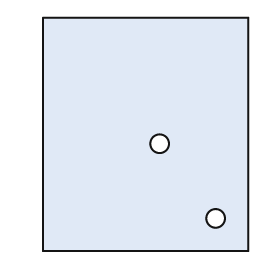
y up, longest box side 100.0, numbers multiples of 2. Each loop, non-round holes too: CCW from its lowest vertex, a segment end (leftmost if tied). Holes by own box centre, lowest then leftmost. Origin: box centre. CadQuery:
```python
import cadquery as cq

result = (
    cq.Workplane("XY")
    .moveTo(-44.0, -50.0)
    .lineTo(44.0, -50.0)
    .lineTo(44.0, 50.0)
    .lineTo(-44.0, 50.0)
    .close()
    .moveTo(30.0, -36.0)
    .circle(4.0)
    .moveTo(6.0, -4.0)
    .circle(4.0)
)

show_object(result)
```